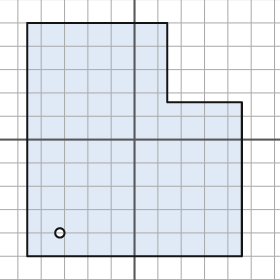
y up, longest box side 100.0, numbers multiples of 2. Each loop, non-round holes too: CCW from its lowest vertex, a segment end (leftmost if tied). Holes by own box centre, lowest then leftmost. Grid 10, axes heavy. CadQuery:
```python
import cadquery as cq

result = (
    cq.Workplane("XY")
    .moveTo(-46.0, -50.0)
    .lineTo(46.0, -50.0)
    .lineTo(46.0, 16.0)
    .lineTo(14.0, 16.0)
    .lineTo(14.0, 50.0)
    .lineTo(-46.0, 50.0)
    .close()
    .moveTo(-32.0, -40.0)
    .circle(2.0)
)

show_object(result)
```